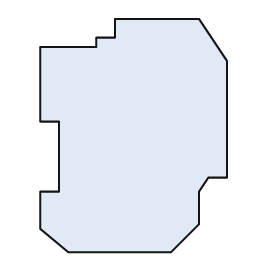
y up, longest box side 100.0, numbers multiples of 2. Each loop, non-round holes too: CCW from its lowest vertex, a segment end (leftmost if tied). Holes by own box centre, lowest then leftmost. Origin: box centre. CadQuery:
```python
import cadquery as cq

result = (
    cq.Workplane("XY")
    .moveTo(-28.0, -50.0)
    .lineTo(16.0, -50.0)
    .lineTo(28.0, -38.0)
    .lineTo(28.0, -24.0)
    .lineTo(32.0, -18.0)
    .lineTo(40.0, -18.0)
    .lineTo(40.0, 32.0)
    .lineTo(28.0, 50.0)
    .lineTo(-8.0, 50.0)
    .lineTo(-8.0, 42.0)
    .lineTo(-16.0, 42.0)
    .lineTo(-16.0, 38.0)
    .lineTo(-40.0, 38.0)
    .lineTo(-40.0, 6.0)
    .lineTo(-32.0, 6.0)
    .lineTo(-32.0, -24.0)
    .lineTo(-40.0, -24.0)
    .lineTo(-40.0, -40.0)
    .close()
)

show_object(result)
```